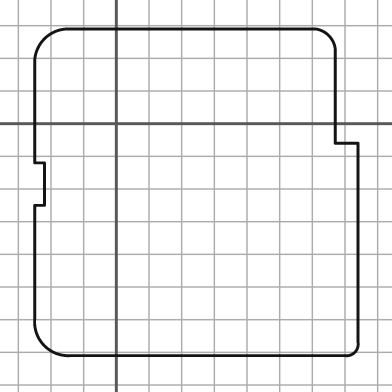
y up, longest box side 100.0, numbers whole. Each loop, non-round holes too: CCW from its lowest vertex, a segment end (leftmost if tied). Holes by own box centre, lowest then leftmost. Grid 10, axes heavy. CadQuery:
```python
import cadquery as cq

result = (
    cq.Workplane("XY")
    .moveTo(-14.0, -71.0)
    .lineTo(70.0, -71.0)
    .threePointArc((73.0, -70.0), (74.0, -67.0))
    .lineTo(74.0, -6.0)
    .lineTo(67.0, -6.0)
    .lineTo(67.0, 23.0)
    .threePointArc((65.0, 27.0), (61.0, 29.0))
    .lineTo(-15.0, 29.0)
    .threePointArc((-22.0, 26.0), (-25.0, 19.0))
    .lineTo(-25.0, -12.0)
    .lineTo(-22.0, -12.0)
    .lineTo(-22.0, -25.0)
    .lineTo(-25.0, -25.0)
    .lineTo(-25.0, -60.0)
    .threePointArc((-22.0, -68.0), (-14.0, -71.0))
    .close()
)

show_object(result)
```